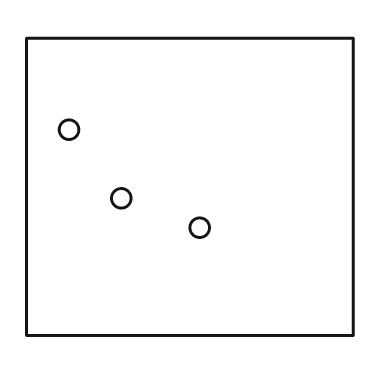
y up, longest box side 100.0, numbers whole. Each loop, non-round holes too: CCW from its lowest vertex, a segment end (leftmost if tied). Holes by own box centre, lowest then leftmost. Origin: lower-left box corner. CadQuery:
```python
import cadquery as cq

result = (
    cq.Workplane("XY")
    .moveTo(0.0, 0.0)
    .lineTo(100.0, 0.0)
    .lineTo(100.0, 91.0)
    .lineTo(0.0, 91.0)
    .close()
    .moveTo(53.0, 33.0)
    .circle(3.0)
    .moveTo(29.0, 42.0)
    .circle(3.0)
    .moveTo(13.0, 63.0)
    .circle(3.0)
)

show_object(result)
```